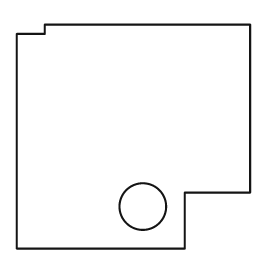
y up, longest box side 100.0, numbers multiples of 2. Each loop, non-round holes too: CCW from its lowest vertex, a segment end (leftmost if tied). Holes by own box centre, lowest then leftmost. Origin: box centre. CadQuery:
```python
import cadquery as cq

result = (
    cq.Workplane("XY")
    .moveTo(-50.0, -48.0)
    .lineTo(22.0, -48.0)
    .lineTo(22.0, -24.0)
    .lineTo(50.0, -24.0)
    .lineTo(50.0, 48.0)
    .lineTo(-38.0, 48.0)
    .lineTo(-38.0, 44.0)
    .lineTo(-50.0, 44.0)
    .close()
    .moveTo(4.0, -30.0)
    .circle(10.0)
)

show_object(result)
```